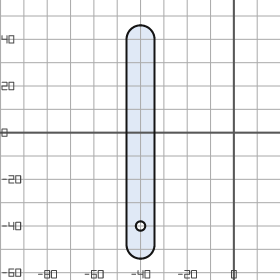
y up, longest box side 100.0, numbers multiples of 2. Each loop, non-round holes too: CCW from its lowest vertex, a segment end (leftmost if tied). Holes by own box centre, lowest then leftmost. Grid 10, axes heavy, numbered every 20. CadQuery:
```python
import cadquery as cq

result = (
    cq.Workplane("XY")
    .moveTo(-46.0, -48.0)
    .threePointArc((-40.0, -54.0), (-34.0, -48.0))
    .lineTo(-34.0, 40.0)
    .threePointArc((-40.0, 46.0), (-46.0, 40.0))
    .close()
    .moveTo(-40.0, -40.0)
    .circle(2.0)
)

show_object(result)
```